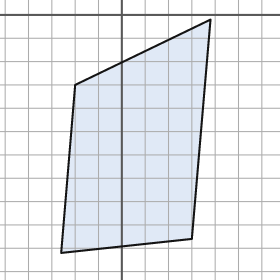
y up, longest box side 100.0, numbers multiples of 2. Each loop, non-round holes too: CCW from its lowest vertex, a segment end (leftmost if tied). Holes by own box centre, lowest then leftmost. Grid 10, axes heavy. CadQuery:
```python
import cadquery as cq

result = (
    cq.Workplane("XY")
    .moveTo(-26.0, -102.0)
    .lineTo(30.0, -96.0)
    .lineTo(38.0, -2.0)
    .lineTo(-20.0, -30.0)
    .close()
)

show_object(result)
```